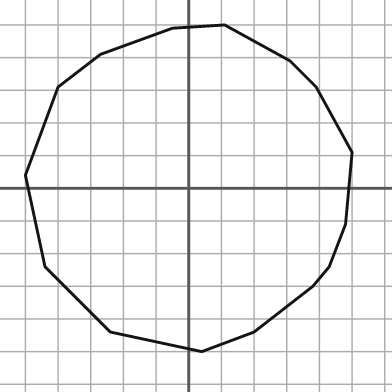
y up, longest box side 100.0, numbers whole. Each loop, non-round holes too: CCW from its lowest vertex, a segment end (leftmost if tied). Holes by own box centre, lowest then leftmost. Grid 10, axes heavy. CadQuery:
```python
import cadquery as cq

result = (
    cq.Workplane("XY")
    .moveTo(4.0, -50.0)
    .lineTo(20.0, -44.0)
    .lineTo(38.0, -30.0)
    .lineTo(43.0, -24.0)
    .lineTo(48.0, -11.0)
    .lineTo(50.0, 11.0)
    .lineTo(39.0, 31.0)
    .lineTo(31.0, 39.0)
    .lineTo(11.0, 50.0)
    .lineTo(-5.0, 49.0)
    .lineTo(-27.0, 41.0)
    .lineTo(-40.0, 31.0)
    .lineTo(-50.0, 4.0)
    .lineTo(-44.0, -24.0)
    .lineTo(-24.0, -44.0)
    .close()
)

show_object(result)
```